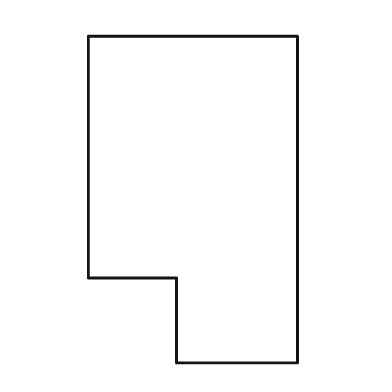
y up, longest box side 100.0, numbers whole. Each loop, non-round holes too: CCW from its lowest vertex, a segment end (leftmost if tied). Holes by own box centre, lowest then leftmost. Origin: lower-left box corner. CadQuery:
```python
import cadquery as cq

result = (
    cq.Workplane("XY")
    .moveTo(27.0, 0.0)
    .lineTo(64.0, 0.0)
    .lineTo(64.0, 100.0)
    .lineTo(0.0, 100.0)
    .lineTo(0.0, 26.0)
    .lineTo(27.0, 26.0)
    .close()
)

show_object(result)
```